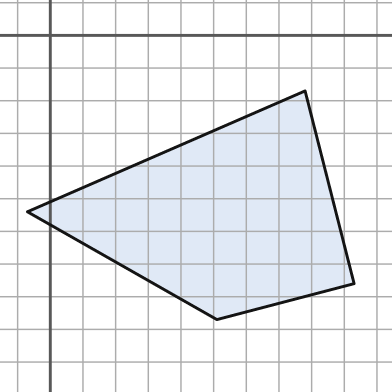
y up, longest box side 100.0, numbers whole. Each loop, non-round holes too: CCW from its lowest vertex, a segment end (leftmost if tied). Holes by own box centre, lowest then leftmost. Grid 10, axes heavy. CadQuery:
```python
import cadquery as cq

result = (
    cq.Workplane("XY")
    .moveTo(51.0, -87.0)
    .lineTo(93.0, -76.0)
    .lineTo(78.0, -17.0)
    .lineTo(-7.0, -54.0)
    .close()
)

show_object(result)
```